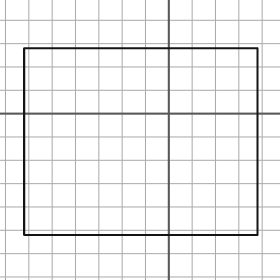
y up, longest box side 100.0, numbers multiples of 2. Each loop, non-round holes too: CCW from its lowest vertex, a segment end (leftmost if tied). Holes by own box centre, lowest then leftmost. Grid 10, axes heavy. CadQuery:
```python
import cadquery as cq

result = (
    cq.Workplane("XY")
    .moveTo(-62.0, -52.0)
    .lineTo(38.0, -52.0)
    .lineTo(38.0, 28.0)
    .lineTo(-62.0, 28.0)
    .close()
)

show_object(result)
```